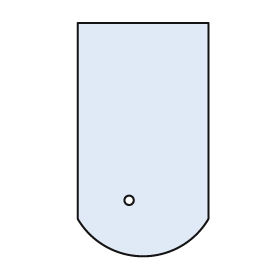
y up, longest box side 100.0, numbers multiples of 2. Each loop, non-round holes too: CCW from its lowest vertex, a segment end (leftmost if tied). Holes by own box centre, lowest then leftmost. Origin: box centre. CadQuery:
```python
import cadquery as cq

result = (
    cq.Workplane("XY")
    .moveTo(-28.0, -34.0)
    .threePointArc((0.0, -50.0), (28.0, -34.0))
    .lineTo(28.0, 50.0)
    .lineTo(-28.0, 50.0)
    .close()
    .moveTo(-6.0, -26.0)
    .circle(2.0)
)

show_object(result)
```